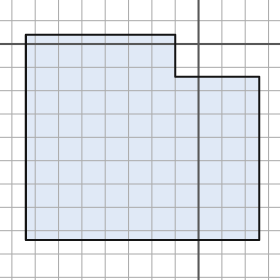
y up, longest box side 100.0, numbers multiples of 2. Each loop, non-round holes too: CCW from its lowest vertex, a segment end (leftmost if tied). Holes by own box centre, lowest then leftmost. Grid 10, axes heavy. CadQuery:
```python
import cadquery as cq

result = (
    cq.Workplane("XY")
    .moveTo(-74.0, -84.0)
    .lineTo(26.0, -84.0)
    .lineTo(26.0, -14.0)
    .lineTo(-10.0, -14.0)
    .lineTo(-10.0, 4.0)
    .lineTo(-74.0, 4.0)
    .close()
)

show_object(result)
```